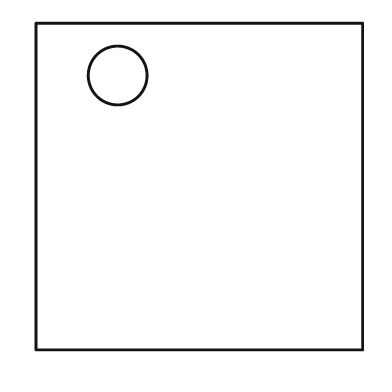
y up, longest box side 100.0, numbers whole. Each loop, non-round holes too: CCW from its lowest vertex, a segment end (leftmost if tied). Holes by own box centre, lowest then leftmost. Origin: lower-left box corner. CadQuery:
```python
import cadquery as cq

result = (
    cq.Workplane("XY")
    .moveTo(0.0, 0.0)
    .lineTo(100.0, 0.0)
    .lineTo(100.0, 100.0)
    .lineTo(0.0, 100.0)
    .close()
    .moveTo(25.0, 84.0)
    .circle(9.0)
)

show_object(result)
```